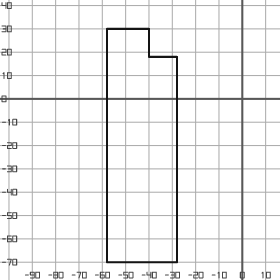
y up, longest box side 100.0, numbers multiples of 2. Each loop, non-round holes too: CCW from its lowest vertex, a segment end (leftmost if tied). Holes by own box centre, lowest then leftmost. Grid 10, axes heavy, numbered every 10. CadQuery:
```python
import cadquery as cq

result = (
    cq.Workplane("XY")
    .moveTo(-58.0, -70.0)
    .lineTo(-28.0, -70.0)
    .lineTo(-28.0, 18.0)
    .lineTo(-40.0, 18.0)
    .lineTo(-40.0, 30.0)
    .lineTo(-58.0, 30.0)
    .close()
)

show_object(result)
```